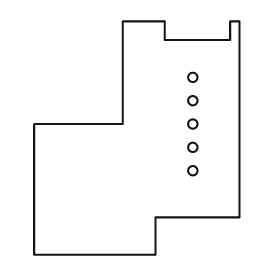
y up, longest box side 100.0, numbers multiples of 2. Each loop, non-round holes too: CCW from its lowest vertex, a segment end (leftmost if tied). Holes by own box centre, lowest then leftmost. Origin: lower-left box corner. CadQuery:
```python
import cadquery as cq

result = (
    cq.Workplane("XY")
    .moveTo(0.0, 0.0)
    .lineTo(52.0, 0.0)
    .lineTo(52.0, 16.0)
    .lineTo(88.0, 16.0)
    .lineTo(88.0, 100.0)
    .lineTo(84.0, 100.0)
    .lineTo(84.0, 92.0)
    .lineTo(56.0, 92.0)
    .lineTo(56.0, 100.0)
    .lineTo(38.0, 100.0)
    .lineTo(38.0, 56.0)
    .lineTo(0.0, 56.0)
    .close()
    .moveTo(68.0, 36.0)
    .circle(2.0)
    .moveTo(68.0, 46.0)
    .circle(2.0)
    .moveTo(68.0, 56.0)
    .circle(2.0)
    .moveTo(68.0, 66.0)
    .circle(2.0)
    .moveTo(68.0, 76.0)
    .circle(2.0)
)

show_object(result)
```